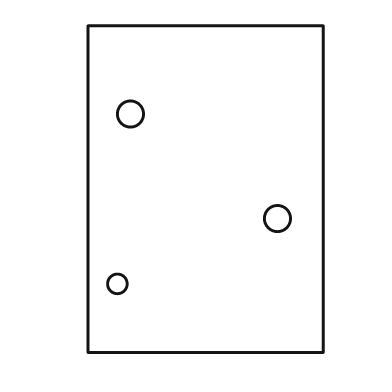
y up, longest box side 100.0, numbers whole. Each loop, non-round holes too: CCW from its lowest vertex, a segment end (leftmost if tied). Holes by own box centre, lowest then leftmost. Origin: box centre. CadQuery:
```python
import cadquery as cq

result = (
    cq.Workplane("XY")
    .moveTo(-36.0, -50.0)
    .lineTo(36.0, -50.0)
    .lineTo(36.0, 50.0)
    .lineTo(-36.0, 50.0)
    .close()
    .moveTo(-27.0, -29.0)
    .circle(3.0)
    .moveTo(22.0, -9.0)
    .circle(4.0)
    .moveTo(-23.0, 23.0)
    .circle(4.0)
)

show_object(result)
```